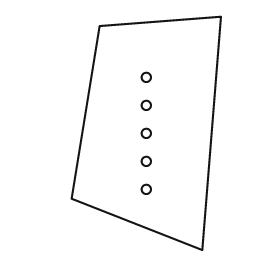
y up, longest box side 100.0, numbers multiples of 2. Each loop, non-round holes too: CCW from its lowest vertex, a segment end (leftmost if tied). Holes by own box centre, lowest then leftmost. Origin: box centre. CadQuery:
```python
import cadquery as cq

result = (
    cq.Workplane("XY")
    .moveTo(24.0, -50.0)
    .lineTo(32.0, 50.0)
    .lineTo(-20.0, 46.0)
    .lineTo(-32.0, -28.0)
    .close()
    .moveTo(0.0, -24.0)
    .circle(2.0)
    .moveTo(0.0, -12.0)
    .circle(2.0)
    .moveTo(0.0, 0.0)
    .circle(2.0)
    .moveTo(0.0, 12.0)
    .circle(2.0)
    .moveTo(0.0, 24.0)
    .circle(2.0)
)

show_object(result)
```